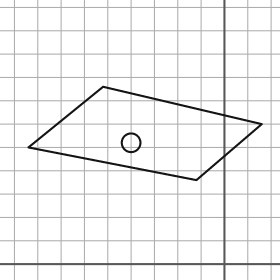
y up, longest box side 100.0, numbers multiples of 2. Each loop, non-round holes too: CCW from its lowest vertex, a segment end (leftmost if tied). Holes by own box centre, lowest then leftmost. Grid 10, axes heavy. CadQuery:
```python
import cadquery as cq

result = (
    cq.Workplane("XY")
    .moveTo(-12.0, 36.0)
    .lineTo(16.0, 60.0)
    .lineTo(-52.0, 76.0)
    .lineTo(-84.0, 50.0)
    .close()
    .moveTo(-40.0, 52.0)
    .circle(4.0)
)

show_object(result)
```